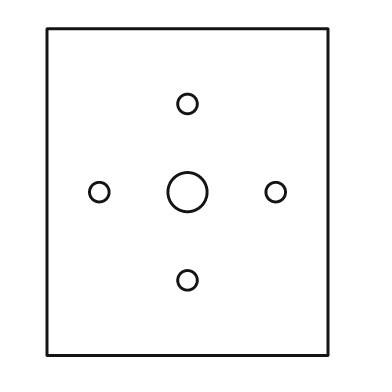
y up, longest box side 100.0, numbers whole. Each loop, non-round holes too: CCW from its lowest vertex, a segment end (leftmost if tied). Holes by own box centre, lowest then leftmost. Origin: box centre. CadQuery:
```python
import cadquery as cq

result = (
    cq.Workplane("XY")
    .moveTo(-43.0, -50.0)
    .lineTo(43.0, -50.0)
    .lineTo(43.0, 50.0)
    .lineTo(-43.0, 50.0)
    .close()
    .moveTo(0.0, -27.0)
    .circle(3.0)
    .moveTo(-27.0, 0.0)
    .circle(3.0)
    .moveTo(0.0, 0.0)
    .circle(6.0)
    .moveTo(27.0, 0.0)
    .circle(3.0)
    .moveTo(0.0, 27.0)
    .circle(3.0)
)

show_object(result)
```